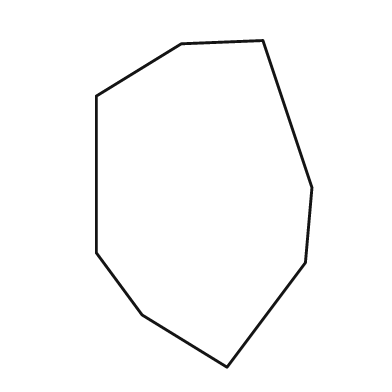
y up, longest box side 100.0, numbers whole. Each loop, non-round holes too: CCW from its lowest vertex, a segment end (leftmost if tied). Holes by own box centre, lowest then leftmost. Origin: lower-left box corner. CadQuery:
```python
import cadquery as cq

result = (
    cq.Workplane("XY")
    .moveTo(40.0, 0.0)
    .lineTo(64.0, 32.0)
    .lineTo(66.0, 55.0)
    .lineTo(51.0, 100.0)
    .lineTo(26.0, 99.0)
    .lineTo(0.0, 83.0)
    .lineTo(0.0, 35.0)
    .lineTo(14.0, 16.0)
    .close()
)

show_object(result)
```